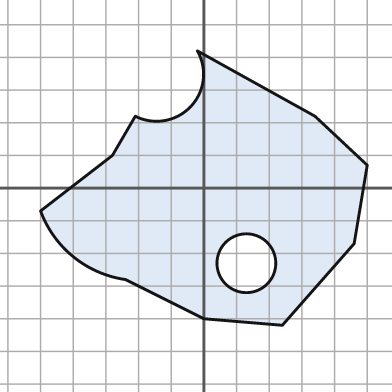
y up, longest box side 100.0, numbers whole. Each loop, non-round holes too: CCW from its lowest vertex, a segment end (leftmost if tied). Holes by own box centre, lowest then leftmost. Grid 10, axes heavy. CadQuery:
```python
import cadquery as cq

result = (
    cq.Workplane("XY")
    .moveTo(24.0, -42.0)
    .lineTo(46.0, -17.0)
    .lineTo(50.0, 7.0)
    .lineTo(34.0, 22.0)
    .lineTo(-2.0, 42.0)
    .threePointArc((-4.0, 25.0), (-21.0, 22.0))
    .lineTo(-28.0, 10.0)
    .lineTo(-50.0, -7.0)
    .threePointArc((-40.0, -21.0), (-24.0, -28.0))
    .lineTo(0.0, -40.0)
    .close()
    .moveTo(13.0, -23.0)
    .circle(9.0)
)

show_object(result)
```